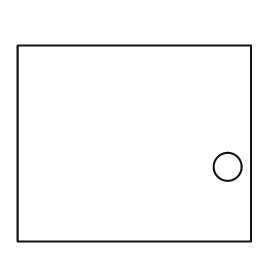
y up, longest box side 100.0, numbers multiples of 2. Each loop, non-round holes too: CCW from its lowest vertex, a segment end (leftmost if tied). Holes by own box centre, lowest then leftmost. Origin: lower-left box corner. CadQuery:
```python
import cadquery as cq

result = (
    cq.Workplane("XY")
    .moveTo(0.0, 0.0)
    .lineTo(100.0, 0.0)
    .lineTo(100.0, 84.0)
    .lineTo(0.0, 84.0)
    .close()
    .moveTo(90.0, 32.0)
    .circle(6.0)
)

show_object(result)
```